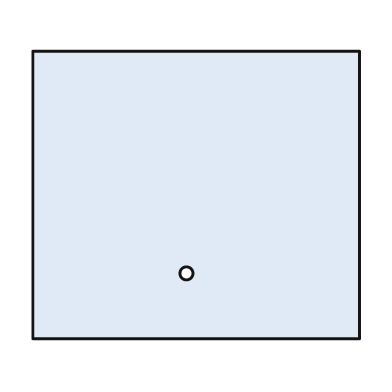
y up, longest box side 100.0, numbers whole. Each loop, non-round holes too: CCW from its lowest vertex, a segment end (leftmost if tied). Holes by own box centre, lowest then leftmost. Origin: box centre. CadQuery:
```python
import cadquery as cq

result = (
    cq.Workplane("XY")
    .moveTo(-50.0, -44.0)
    .lineTo(50.0, -44.0)
    .lineTo(50.0, 44.0)
    .lineTo(-50.0, 44.0)
    .close()
    .moveTo(-3.0, -24.0)
    .circle(2.0)
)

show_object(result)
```